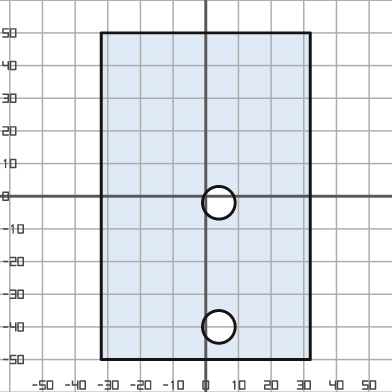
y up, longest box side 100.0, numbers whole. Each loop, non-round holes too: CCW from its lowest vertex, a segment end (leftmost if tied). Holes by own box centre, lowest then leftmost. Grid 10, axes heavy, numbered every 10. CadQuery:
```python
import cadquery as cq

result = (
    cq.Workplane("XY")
    .moveTo(-32.0, -50.0)
    .lineTo(32.0, -50.0)
    .lineTo(32.0, 50.0)
    .lineTo(-32.0, 50.0)
    .close()
    .moveTo(4.0, -40.0)
    .circle(5.0)
    .moveTo(4.0, -2.0)
    .circle(5.0)
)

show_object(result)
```